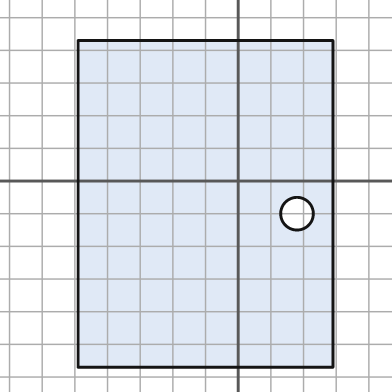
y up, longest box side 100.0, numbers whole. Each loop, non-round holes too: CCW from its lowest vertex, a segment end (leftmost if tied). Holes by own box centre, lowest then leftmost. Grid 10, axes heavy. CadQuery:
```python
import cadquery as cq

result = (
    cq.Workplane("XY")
    .moveTo(-49.0, -57.0)
    .lineTo(29.0, -57.0)
    .lineTo(29.0, 43.0)
    .lineTo(-49.0, 43.0)
    .close()
    .moveTo(18.0, -10.0)
    .circle(5.0)
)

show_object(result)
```